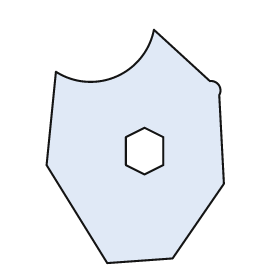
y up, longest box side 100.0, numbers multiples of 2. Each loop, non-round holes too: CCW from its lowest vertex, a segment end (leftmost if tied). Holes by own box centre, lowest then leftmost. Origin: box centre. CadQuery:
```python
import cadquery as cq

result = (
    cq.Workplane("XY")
    .moveTo(-12.0, -50.0)
    .lineTo(16.0, -48.0)
    .lineTo(38.0, -16.0)
    .lineTo(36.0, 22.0)
    .threePointArc((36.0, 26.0), (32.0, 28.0))
    .lineTo(8.0, 50.0)
    .threePointArc((-8.0, 30.0), (-34.0, 32.0))
    .lineTo(-38.0, -8.0)
    .close()
    .moveTo(4.0, -12.0)
    .lineTo(12.0, -8.0)
    .lineTo(12.0, 4.0)
    .lineTo(4.0, 8.0)
    .lineTo(-4.0, 4.0)
    .lineTo(-4.0, -8.0)
    .close()
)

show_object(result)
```